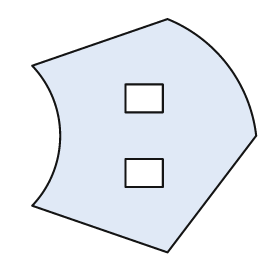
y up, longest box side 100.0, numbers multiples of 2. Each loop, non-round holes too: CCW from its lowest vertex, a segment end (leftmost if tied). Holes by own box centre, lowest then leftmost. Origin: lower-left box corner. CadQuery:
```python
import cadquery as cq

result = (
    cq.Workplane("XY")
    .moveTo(58.0, 0.0)
    .lineTo(96.0, 50.0)
    .threePointArc((84.0, 80.0), (58.0, 100.0))
    .lineTo(0.0, 80.0)
    .threePointArc((12.0, 50.0), (0.0, 20.0))
    .close()
    .moveTo(40.0, 28.0)
    .lineTo(56.0, 28.0)
    .lineTo(56.0, 40.0)
    .lineTo(40.0, 40.0)
    .close()
    .moveTo(40.0, 60.0)
    .lineTo(56.0, 60.0)
    .lineTo(56.0, 72.0)
    .lineTo(40.0, 72.0)
    .close()
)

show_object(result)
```